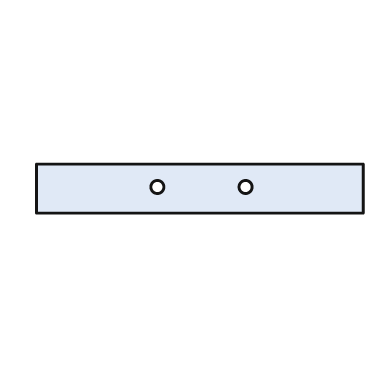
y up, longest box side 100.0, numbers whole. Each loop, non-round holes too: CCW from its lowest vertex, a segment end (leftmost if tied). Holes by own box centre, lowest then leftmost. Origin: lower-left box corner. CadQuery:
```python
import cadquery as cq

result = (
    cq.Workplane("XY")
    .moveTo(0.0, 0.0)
    .lineTo(100.0, 0.0)
    .lineTo(100.0, 15.0)
    .lineTo(0.0, 15.0)
    .close()
    .moveTo(37.0, 8.0)
    .circle(2.0)
    .moveTo(64.0, 8.0)
    .circle(2.0)
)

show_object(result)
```